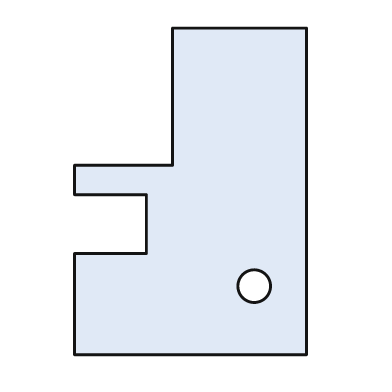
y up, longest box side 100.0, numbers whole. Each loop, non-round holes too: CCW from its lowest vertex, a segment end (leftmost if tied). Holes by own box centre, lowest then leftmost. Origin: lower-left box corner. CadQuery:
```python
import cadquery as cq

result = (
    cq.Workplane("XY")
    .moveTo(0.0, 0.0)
    .lineTo(71.0, 0.0)
    .lineTo(71.0, 100.0)
    .lineTo(30.0, 100.0)
    .lineTo(30.0, 58.0)
    .lineTo(0.0, 58.0)
    .lineTo(0.0, 49.0)
    .lineTo(22.0, 49.0)
    .lineTo(22.0, 31.0)
    .lineTo(0.0, 31.0)
    .close()
    .moveTo(55.0, 21.0)
    .circle(5.0)
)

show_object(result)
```